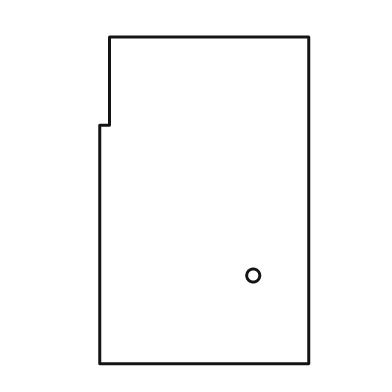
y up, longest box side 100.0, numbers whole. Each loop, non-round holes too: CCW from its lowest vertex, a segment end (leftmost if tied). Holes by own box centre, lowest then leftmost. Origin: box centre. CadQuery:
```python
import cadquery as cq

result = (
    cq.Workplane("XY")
    .moveTo(-32.0, -50.0)
    .lineTo(32.0, -50.0)
    .lineTo(32.0, 50.0)
    .lineTo(-29.0, 50.0)
    .lineTo(-29.0, 23.0)
    .lineTo(-32.0, 23.0)
    .close()
    .moveTo(15.0, -23.0)
    .circle(2.0)
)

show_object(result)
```